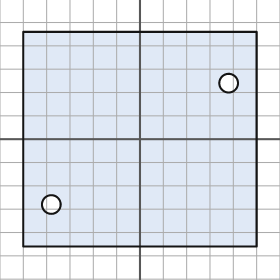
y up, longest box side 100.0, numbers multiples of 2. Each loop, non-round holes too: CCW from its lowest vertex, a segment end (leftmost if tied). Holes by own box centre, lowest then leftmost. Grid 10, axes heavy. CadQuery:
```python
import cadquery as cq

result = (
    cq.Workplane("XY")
    .moveTo(-50.0, -46.0)
    .lineTo(50.0, -46.0)
    .lineTo(50.0, 46.0)
    .lineTo(-50.0, 46.0)
    .close()
    .moveTo(-38.0, -28.0)
    .circle(4.0)
    .moveTo(38.0, 24.0)
    .circle(4.0)
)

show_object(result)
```